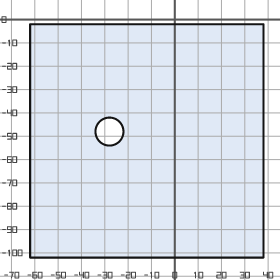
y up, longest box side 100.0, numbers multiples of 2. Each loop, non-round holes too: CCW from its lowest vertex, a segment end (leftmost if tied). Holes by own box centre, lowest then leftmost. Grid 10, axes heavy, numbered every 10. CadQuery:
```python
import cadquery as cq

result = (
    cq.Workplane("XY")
    .moveTo(-62.0, -102.0)
    .lineTo(38.0, -102.0)
    .lineTo(38.0, -2.0)
    .lineTo(-62.0, -2.0)
    .close()
    .moveTo(-28.0, -48.0)
    .circle(6.0)
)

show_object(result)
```